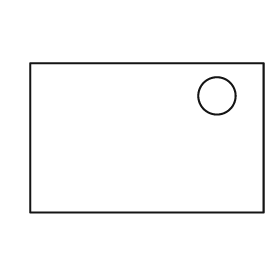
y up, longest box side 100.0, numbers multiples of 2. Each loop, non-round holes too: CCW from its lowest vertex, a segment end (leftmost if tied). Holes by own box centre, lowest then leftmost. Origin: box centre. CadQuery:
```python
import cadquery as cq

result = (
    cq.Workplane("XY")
    .moveTo(-50.0, -32.0)
    .lineTo(50.0, -32.0)
    .lineTo(50.0, 32.0)
    .lineTo(-50.0, 32.0)
    .close()
    .moveTo(30.0, 18.0)
    .circle(8.0)
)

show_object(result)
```